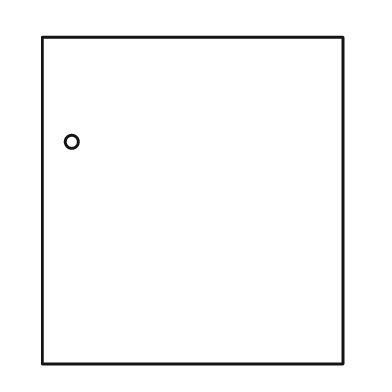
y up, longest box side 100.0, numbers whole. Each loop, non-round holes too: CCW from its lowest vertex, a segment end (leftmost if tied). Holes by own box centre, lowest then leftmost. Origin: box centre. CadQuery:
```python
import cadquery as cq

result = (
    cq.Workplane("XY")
    .moveTo(-46.0, -50.0)
    .lineTo(46.0, -50.0)
    .lineTo(46.0, 50.0)
    .lineTo(-46.0, 50.0)
    .close()
    .moveTo(-37.0, 18.0)
    .circle(2.0)
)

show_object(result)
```